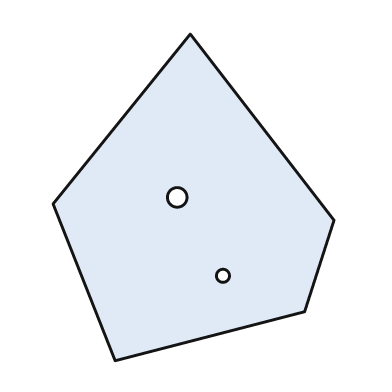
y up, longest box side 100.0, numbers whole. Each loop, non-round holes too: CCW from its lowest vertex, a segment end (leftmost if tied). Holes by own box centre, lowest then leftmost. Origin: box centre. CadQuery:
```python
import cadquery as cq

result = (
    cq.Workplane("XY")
    .moveTo(-24.0, -50.0)
    .lineTo(34.0, -35.0)
    .lineTo(43.0, -7.0)
    .lineTo(-1.0, 50.0)
    .lineTo(-43.0, -2.0)
    .close()
    .moveTo(9.0, -24.0)
    .circle(2.0)
    .moveTo(-5.0, 0.0)
    .circle(3.0)
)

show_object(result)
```